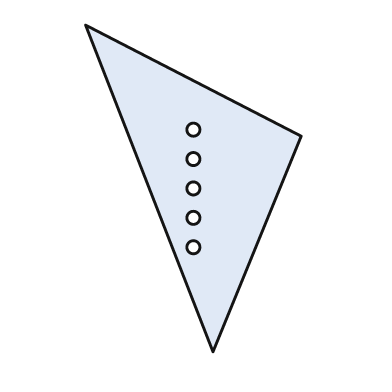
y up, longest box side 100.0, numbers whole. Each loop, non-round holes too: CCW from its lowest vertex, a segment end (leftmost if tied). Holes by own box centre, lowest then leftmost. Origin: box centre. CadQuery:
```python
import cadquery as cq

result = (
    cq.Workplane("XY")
    .moveTo(6.0, -50.0)
    .lineTo(33.0, 16.0)
    .lineTo(-33.0, 50.0)
    .close()
    .moveTo(0.0, -18.0)
    .circle(2.0)
    .moveTo(0.0, -9.0)
    .circle(2.0)
    .moveTo(0.0, 0.0)
    .circle(2.0)
    .moveTo(0.0, 9.0)
    .circle(2.0)
    .moveTo(0.0, 18.0)
    .circle(2.0)
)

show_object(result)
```